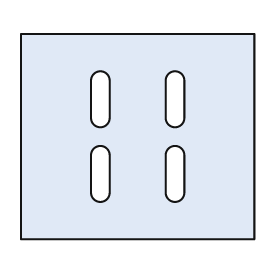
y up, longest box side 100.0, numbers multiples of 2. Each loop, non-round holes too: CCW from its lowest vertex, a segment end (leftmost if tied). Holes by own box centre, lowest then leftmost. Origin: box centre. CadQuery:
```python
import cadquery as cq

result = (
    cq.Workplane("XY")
    .moveTo(-50.0, -44.0)
    .lineTo(50.0, -44.0)
    .lineTo(50.0, 44.0)
    .lineTo(-50.0, 44.0)
    .close()
    .moveTo(-20.0, -24.0)
    .threePointArc((-16.0, -28.0), (-12.0, -24.0))
    .lineTo(-12.0, -8.0)
    .threePointArc((-16.0, -4.0), (-20.0, -8.0))
    .close()
    .moveTo(12.0, -24.0)
    .threePointArc((16.0, -28.0), (20.0, -24.0))
    .lineTo(20.0, -8.0)
    .threePointArc((16.0, -4.0), (12.0, -8.0))
    .close()
    .moveTo(-20.0, 8.0)
    .threePointArc((-16.0, 4.0), (-12.0, 8.0))
    .lineTo(-12.0, 24.0)
    .threePointArc((-16.0, 28.0), (-20.0, 24.0))
    .close()
    .moveTo(12.0, 8.0)
    .threePointArc((16.0, 4.0), (20.0, 8.0))
    .lineTo(20.0, 24.0)
    .threePointArc((16.0, 28.0), (12.0, 24.0))
    .close()
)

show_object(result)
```